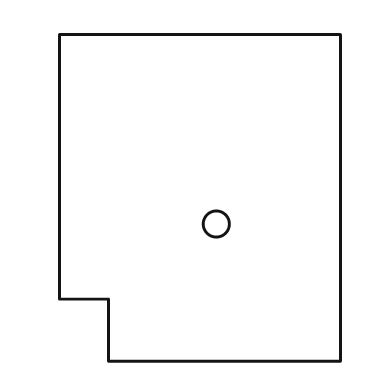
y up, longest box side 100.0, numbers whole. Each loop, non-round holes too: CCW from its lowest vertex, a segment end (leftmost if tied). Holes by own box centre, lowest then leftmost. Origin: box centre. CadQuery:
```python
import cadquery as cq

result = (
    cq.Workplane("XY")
    .moveTo(-28.0, -50.0)
    .lineTo(43.0, -50.0)
    .lineTo(43.0, 50.0)
    .lineTo(-43.0, 50.0)
    .lineTo(-43.0, -31.0)
    .lineTo(-28.0, -31.0)
    .close()
    .moveTo(5.0, -8.0)
    .circle(4.0)
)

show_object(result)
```